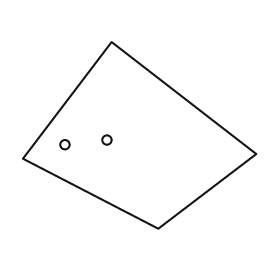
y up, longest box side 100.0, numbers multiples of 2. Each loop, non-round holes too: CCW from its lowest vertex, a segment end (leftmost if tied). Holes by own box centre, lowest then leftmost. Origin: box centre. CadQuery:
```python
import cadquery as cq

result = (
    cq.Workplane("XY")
    .moveTo(8.0, -40.0)
    .lineTo(50.0, -8.0)
    .lineTo(-12.0, 40.0)
    .lineTo(-50.0, -10.0)
    .close()
    .moveTo(-32.0, -4.0)
    .circle(2.0)
    .moveTo(-14.0, -2.0)
    .circle(2.0)
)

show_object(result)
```